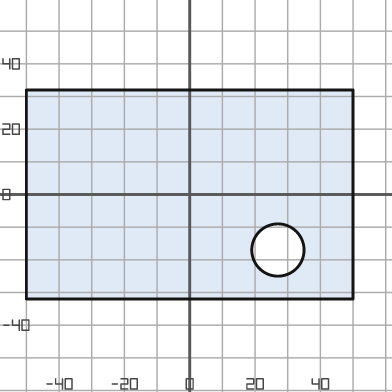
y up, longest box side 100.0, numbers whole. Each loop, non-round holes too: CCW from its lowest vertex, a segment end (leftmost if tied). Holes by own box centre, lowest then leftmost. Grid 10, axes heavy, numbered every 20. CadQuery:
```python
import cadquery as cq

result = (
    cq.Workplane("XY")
    .moveTo(-50.0, -32.0)
    .lineTo(50.0, -32.0)
    .lineTo(50.0, 32.0)
    .lineTo(-50.0, 32.0)
    .close()
    .moveTo(27.0, -17.0)
    .circle(8.0)
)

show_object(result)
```